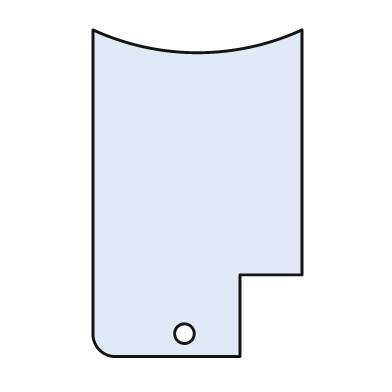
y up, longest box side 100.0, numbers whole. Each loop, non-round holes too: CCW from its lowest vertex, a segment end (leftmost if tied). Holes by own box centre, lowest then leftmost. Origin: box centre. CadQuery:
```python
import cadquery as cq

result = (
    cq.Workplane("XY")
    .moveTo(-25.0, -50.0)
    .lineTo(13.0, -50.0)
    .lineTo(13.0, -25.0)
    .lineTo(32.0, -25.0)
    .lineTo(32.0, 50.0)
    .threePointArc((0.0, 43.0), (-32.0, 50.0))
    .lineTo(-32.0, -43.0)
    .threePointArc((-30.0, -48.0), (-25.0, -50.0))
    .close()
    .moveTo(-4.0, -43.0)
    .circle(3.0)
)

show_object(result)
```